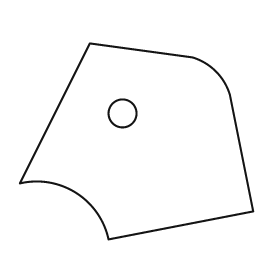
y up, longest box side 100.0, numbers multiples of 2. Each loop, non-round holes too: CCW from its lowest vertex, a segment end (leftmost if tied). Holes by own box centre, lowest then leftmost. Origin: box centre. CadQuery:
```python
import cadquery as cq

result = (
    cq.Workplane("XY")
    .moveTo(-12.0, -42.0)
    .lineTo(50.0, -30.0)
    .lineTo(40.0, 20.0)
    .threePointArc((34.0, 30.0), (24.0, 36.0))
    .lineTo(-20.0, 42.0)
    .lineTo(-50.0, -18.0)
    .threePointArc((-26.0, -22.0), (-12.0, -42.0))
    .close()
    .moveTo(-6.0, 12.0)
    .circle(6.0)
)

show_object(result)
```